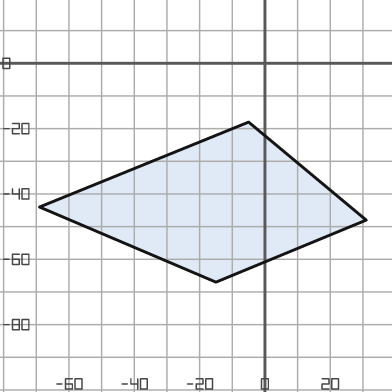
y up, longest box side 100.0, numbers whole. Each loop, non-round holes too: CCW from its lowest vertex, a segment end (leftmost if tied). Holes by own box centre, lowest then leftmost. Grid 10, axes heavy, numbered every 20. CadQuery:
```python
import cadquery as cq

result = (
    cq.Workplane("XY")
    .moveTo(-15.0, -67.0)
    .lineTo(31.0, -48.0)
    .lineTo(-5.0, -18.0)
    .lineTo(-69.0, -44.0)
    .close()
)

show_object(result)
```